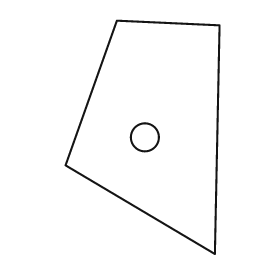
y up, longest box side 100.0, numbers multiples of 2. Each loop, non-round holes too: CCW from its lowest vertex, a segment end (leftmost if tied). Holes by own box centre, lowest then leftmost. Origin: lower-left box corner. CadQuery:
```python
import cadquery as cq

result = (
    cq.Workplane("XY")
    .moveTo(64.0, 0.0)
    .lineTo(66.0, 98.0)
    .lineTo(22.0, 100.0)
    .lineTo(0.0, 38.0)
    .close()
    .moveTo(34.0, 50.0)
    .circle(6.0)
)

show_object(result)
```